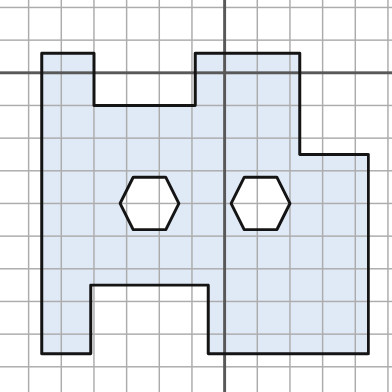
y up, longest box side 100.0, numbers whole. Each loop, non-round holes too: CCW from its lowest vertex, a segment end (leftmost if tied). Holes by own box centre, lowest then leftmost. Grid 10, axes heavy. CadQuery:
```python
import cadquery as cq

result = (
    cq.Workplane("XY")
    .moveTo(-56.0, -86.0)
    .lineTo(-41.0, -86.0)
    .lineTo(-41.0, -65.0)
    .lineTo(-5.0, -65.0)
    .lineTo(-5.0, -86.0)
    .lineTo(44.0, -86.0)
    .lineTo(44.0, -25.0)
    .lineTo(23.0, -25.0)
    .lineTo(23.0, 6.0)
    .lineTo(-9.0, 6.0)
    .lineTo(-9.0, -10.0)
    .lineTo(-40.0, -10.0)
    .lineTo(-40.0, 6.0)
    .lineTo(-56.0, 6.0)
    .close()
    .moveTo(-28.0, -48.0)
    .lineTo(-18.0, -48.0)
    .lineTo(-14.0, -40.0)
    .lineTo(-18.0, -32.0)
    .lineTo(-28.0, -32.0)
    .lineTo(-32.0, -40.0)
    .close()
    .moveTo(6.0, -48.0)
    .lineTo(16.0, -48.0)
    .lineTo(20.0, -40.0)
    .lineTo(16.0, -32.0)
    .lineTo(6.0, -32.0)
    .lineTo(2.0, -40.0)
    .close()
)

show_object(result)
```